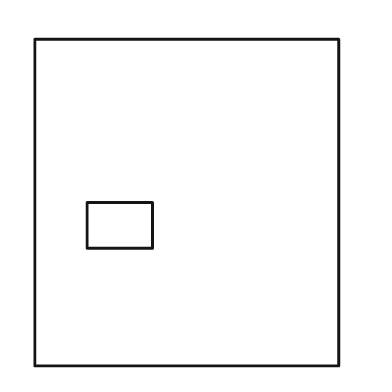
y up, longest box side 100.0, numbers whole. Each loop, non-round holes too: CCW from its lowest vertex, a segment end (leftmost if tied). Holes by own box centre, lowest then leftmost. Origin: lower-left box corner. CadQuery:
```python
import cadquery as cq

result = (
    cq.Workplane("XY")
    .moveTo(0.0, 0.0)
    .lineTo(93.0, 0.0)
    .lineTo(93.0, 100.0)
    .lineTo(0.0, 100.0)
    .close()
    .moveTo(16.0, 36.0)
    .lineTo(36.0, 36.0)
    .lineTo(36.0, 50.0)
    .lineTo(16.0, 50.0)
    .close()
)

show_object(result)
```